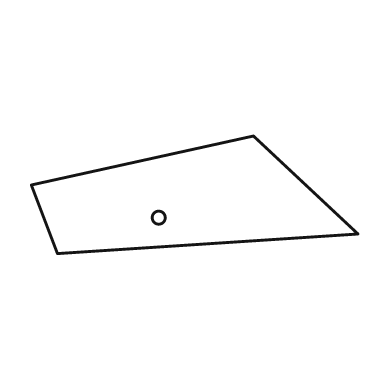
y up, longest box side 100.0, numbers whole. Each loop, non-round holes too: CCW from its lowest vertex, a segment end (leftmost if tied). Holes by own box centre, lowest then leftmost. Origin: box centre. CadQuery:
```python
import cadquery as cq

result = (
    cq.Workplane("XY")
    .moveTo(-42.0, -18.0)
    .lineTo(50.0, -12.0)
    .lineTo(18.0, 18.0)
    .lineTo(-50.0, 3.0)
    .close()
    .moveTo(-11.0, -7.0)
    .circle(2.0)
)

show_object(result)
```